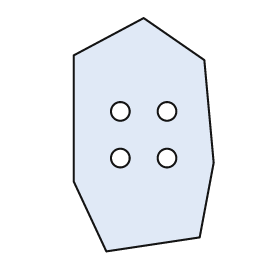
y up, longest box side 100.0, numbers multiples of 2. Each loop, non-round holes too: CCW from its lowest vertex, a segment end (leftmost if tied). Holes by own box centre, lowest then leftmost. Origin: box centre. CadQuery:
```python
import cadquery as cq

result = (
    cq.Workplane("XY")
    .moveTo(-16.0, -50.0)
    .lineTo(24.0, -44.0)
    .lineTo(30.0, -12.0)
    .lineTo(26.0, 32.0)
    .lineTo(0.0, 50.0)
    .lineTo(-30.0, 34.0)
    .lineTo(-30.0, -20.0)
    .close()
    .moveTo(-10.0, -10.0)
    .circle(4.0)
    .moveTo(10.0, -10.0)
    .circle(4.0)
    .moveTo(-10.0, 10.0)
    .circle(4.0)
    .moveTo(10.0, 10.0)
    .circle(4.0)
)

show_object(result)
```